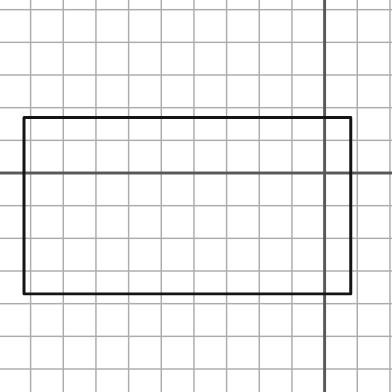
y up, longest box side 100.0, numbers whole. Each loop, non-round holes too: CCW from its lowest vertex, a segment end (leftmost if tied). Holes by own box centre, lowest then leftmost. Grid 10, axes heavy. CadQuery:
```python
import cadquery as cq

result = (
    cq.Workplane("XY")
    .moveTo(-92.0, -37.0)
    .lineTo(8.0, -37.0)
    .lineTo(8.0, 17.0)
    .lineTo(-92.0, 17.0)
    .close()
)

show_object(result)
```